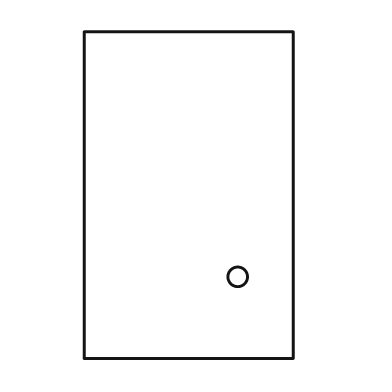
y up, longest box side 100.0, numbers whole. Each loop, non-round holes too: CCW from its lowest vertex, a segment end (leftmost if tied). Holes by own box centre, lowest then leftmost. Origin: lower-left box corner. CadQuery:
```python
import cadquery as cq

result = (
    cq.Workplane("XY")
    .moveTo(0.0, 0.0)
    .lineTo(64.0, 0.0)
    .lineTo(64.0, 100.0)
    .lineTo(0.0, 100.0)
    .close()
    .moveTo(47.0, 25.0)
    .circle(3.0)
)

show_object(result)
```